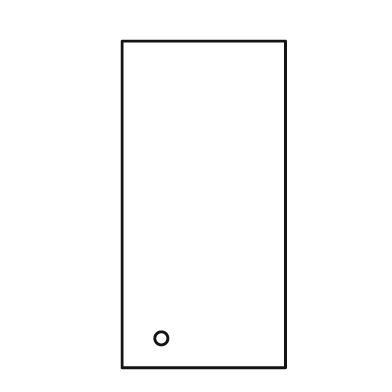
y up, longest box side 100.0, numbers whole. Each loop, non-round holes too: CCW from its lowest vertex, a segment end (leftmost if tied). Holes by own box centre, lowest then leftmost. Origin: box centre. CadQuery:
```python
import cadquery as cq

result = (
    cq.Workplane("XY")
    .moveTo(-25.0, -50.0)
    .lineTo(25.0, -50.0)
    .lineTo(25.0, 50.0)
    .lineTo(-25.0, 50.0)
    .close()
    .moveTo(-13.0, -41.0)
    .circle(2.0)
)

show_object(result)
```